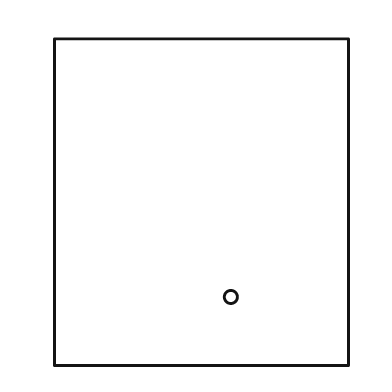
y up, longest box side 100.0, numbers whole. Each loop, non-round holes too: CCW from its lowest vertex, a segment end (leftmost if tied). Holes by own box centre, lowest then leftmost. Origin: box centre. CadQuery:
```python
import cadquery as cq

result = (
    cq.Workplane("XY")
    .moveTo(-45.0, -50.0)
    .lineTo(45.0, -50.0)
    .lineTo(45.0, 50.0)
    .lineTo(-45.0, 50.0)
    .close()
    .moveTo(9.0, -29.0)
    .circle(2.0)
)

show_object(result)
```